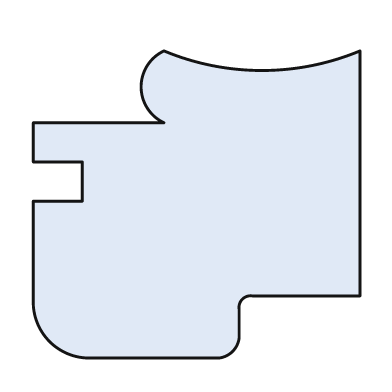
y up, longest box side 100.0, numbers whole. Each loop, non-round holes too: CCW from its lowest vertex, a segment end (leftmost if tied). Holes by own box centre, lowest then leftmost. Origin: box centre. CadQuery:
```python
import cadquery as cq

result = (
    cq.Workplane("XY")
    .moveTo(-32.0, -47.0)
    .lineTo(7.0, -47.0)
    .threePointArc((11.0, -45.0), (13.0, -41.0))
    .lineTo(13.0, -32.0)
    .threePointArc((14.0, -29.0), (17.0, -28.0))
    .lineTo(50.0, -28.0)
    .lineTo(50.0, 47.0)
    .threePointArc((20.0, 41.0), (-10.0, 47.0))
    .threePointArc((-17.0, 36.0), (-10.0, 25.0))
    .lineTo(-50.0, 25.0)
    .lineTo(-50.0, 13.0)
    .lineTo(-35.0, 13.0)
    .lineTo(-35.0, 1.0)
    .lineTo(-50.0, 1.0)
    .lineTo(-50.0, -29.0)
    .threePointArc((-45.0, -42.0), (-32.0, -47.0))
    .close()
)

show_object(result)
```